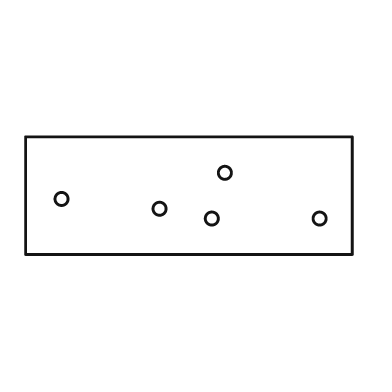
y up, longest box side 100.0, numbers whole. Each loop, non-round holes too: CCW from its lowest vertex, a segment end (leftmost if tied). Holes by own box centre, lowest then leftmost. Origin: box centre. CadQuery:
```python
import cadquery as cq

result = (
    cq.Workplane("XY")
    .moveTo(-50.0, -18.0)
    .lineTo(50.0, -18.0)
    .lineTo(50.0, 18.0)
    .lineTo(-50.0, 18.0)
    .close()
    .moveTo(7.0, -7.0)
    .circle(2.0)
    .moveTo(40.0, -7.0)
    .circle(2.0)
    .moveTo(-9.0, -4.0)
    .circle(2.0)
    .moveTo(-39.0, -1.0)
    .circle(2.0)
    .moveTo(11.0, 7.0)
    .circle(2.0)
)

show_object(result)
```